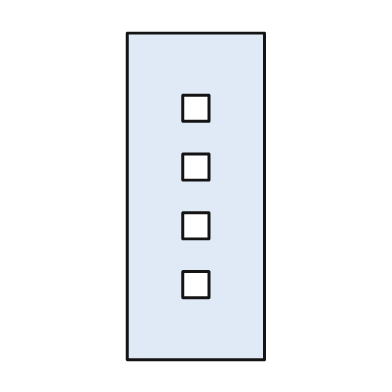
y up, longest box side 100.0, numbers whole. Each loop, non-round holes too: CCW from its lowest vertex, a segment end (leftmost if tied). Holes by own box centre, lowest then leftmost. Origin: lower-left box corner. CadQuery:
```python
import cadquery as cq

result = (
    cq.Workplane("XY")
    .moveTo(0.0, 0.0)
    .lineTo(42.0, 0.0)
    .lineTo(42.0, 100.0)
    .lineTo(0.0, 100.0)
    .close()
    .moveTo(17.0, 19.0)
    .lineTo(25.0, 19.0)
    .lineTo(25.0, 27.0)
    .lineTo(17.0, 27.0)
    .close()
    .moveTo(17.0, 37.0)
    .lineTo(25.0, 37.0)
    .lineTo(25.0, 45.0)
    .lineTo(17.0, 45.0)
    .close()
    .moveTo(17.0, 55.0)
    .lineTo(25.0, 55.0)
    .lineTo(25.0, 63.0)
    .lineTo(17.0, 63.0)
    .close()
    .moveTo(17.0, 73.0)
    .lineTo(25.0, 73.0)
    .lineTo(25.0, 81.0)
    .lineTo(17.0, 81.0)
    .close()
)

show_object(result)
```